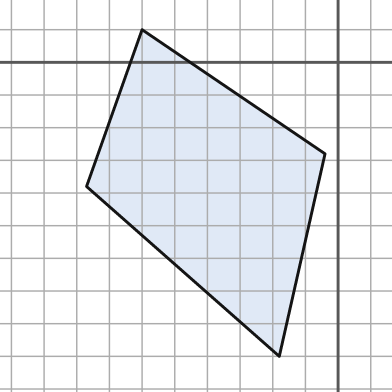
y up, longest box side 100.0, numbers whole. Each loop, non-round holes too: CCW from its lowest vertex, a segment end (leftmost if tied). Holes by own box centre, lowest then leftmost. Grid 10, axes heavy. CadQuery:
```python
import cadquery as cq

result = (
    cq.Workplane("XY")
    .moveTo(-18.0, -90.0)
    .lineTo(-4.0, -28.0)
    .lineTo(-60.0, 10.0)
    .lineTo(-77.0, -38.0)
    .close()
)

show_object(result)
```